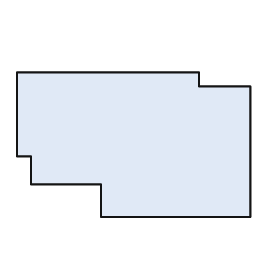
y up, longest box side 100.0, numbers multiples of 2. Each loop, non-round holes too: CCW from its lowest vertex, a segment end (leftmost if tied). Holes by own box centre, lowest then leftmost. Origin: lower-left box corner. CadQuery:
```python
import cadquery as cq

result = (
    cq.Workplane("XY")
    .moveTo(36.0, 0.0)
    .lineTo(100.0, 0.0)
    .lineTo(100.0, 56.0)
    .lineTo(78.0, 56.0)
    .lineTo(78.0, 62.0)
    .lineTo(0.0, 62.0)
    .lineTo(0.0, 26.0)
    .lineTo(6.0, 26.0)
    .lineTo(6.0, 14.0)
    .lineTo(36.0, 14.0)
    .close()
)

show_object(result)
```